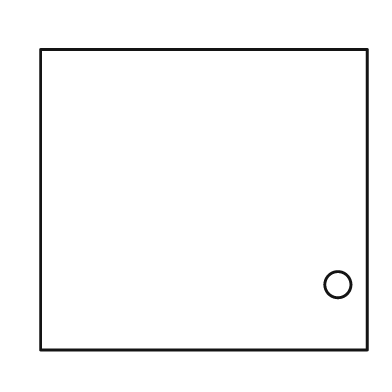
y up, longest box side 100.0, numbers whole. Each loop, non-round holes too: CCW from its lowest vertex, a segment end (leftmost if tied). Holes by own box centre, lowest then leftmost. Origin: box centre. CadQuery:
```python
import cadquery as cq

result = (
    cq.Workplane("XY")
    .moveTo(-50.0, -46.0)
    .lineTo(50.0, -46.0)
    .lineTo(50.0, 46.0)
    .lineTo(-50.0, 46.0)
    .close()
    .moveTo(41.0, -26.0)
    .circle(4.0)
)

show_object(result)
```